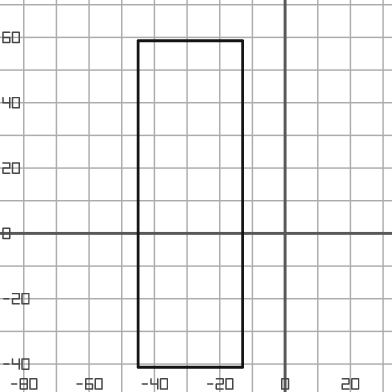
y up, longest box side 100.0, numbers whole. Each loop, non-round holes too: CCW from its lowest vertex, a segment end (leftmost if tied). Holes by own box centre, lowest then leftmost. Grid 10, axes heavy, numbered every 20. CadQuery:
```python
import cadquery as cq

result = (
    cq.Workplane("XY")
    .moveTo(-45.0, -41.0)
    .lineTo(-13.0, -41.0)
    .lineTo(-13.0, 59.0)
    .lineTo(-45.0, 59.0)
    .close()
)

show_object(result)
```